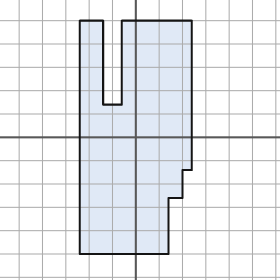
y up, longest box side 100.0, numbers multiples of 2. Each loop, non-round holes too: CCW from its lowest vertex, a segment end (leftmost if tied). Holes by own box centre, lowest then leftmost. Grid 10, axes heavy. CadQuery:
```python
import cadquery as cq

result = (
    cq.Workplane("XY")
    .moveTo(-24.0, -50.0)
    .lineTo(14.0, -50.0)
    .lineTo(14.0, -26.0)
    .lineTo(20.0, -26.0)
    .lineTo(20.0, -14.0)
    .lineTo(24.0, -14.0)
    .lineTo(24.0, 50.0)
    .lineTo(-6.0, 50.0)
    .lineTo(-6.0, 14.0)
    .lineTo(-14.0, 14.0)
    .lineTo(-14.0, 50.0)
    .lineTo(-24.0, 50.0)
    .close()
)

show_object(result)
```